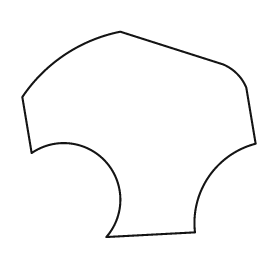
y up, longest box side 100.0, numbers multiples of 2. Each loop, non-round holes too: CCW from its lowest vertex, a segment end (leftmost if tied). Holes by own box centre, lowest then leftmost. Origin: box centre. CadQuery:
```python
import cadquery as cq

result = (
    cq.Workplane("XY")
    .moveTo(-14.0, -44.0)
    .lineTo(24.0, -42.0)
    .threePointArc((30.0, -18.0), (50.0, -4.0))
    .lineTo(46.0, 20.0)
    .threePointArc((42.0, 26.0), (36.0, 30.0))
    .lineTo(-8.0, 44.0)
    .threePointArc((-32.0, 34.0), (-50.0, 16.0))
    .lineTo(-46.0, -8.0)
    .threePointArc((-14.0, -12.0), (-14.0, -44.0))
    .close()
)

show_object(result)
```